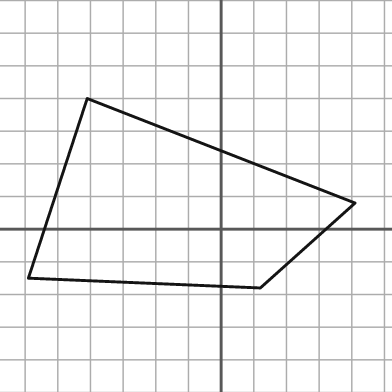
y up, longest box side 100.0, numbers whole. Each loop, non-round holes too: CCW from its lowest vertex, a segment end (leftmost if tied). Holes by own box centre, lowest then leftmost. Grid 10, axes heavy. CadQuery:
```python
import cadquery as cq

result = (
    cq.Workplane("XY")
    .moveTo(12.0, -18.0)
    .lineTo(41.0, 8.0)
    .lineTo(-41.0, 40.0)
    .lineTo(-59.0, -15.0)
    .close()
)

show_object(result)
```